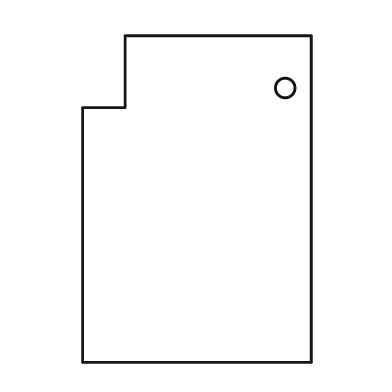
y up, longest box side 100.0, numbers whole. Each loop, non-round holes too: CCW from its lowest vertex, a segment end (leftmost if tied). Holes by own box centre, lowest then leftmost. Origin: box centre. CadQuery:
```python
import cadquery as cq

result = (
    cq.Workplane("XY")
    .moveTo(-35.0, -50.0)
    .lineTo(35.0, -50.0)
    .lineTo(35.0, 50.0)
    .lineTo(-22.0, 50.0)
    .lineTo(-22.0, 28.0)
    .lineTo(-35.0, 28.0)
    .close()
    .moveTo(27.0, 34.0)
    .circle(3.0)
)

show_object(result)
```